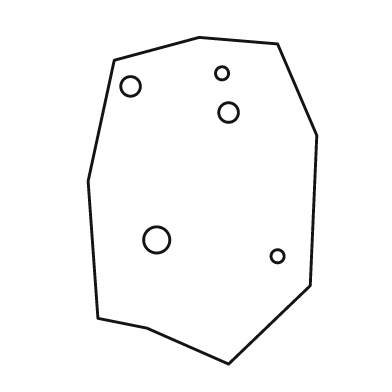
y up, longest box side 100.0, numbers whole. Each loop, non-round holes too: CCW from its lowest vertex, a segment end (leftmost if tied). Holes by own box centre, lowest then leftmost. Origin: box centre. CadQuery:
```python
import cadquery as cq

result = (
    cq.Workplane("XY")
    .moveTo(8.0, -50.0)
    .lineTo(33.0, -26.0)
    .lineTo(35.0, 20.0)
    .lineTo(23.0, 48.0)
    .lineTo(-1.0, 50.0)
    .lineTo(-27.0, 43.0)
    .lineTo(-35.0, 6.0)
    .lineTo(-32.0, -36.0)
    .lineTo(-17.0, -39.0)
    .close()
    .moveTo(23.0, -17.0)
    .circle(2.0)
    .moveTo(-14.0, -12.0)
    .circle(4.0)
    .moveTo(8.0, 27.0)
    .circle(3.0)
    .moveTo(-22.0, 35.0)
    .circle(3.0)
    .moveTo(6.0, 39.0)
    .circle(2.0)
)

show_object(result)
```